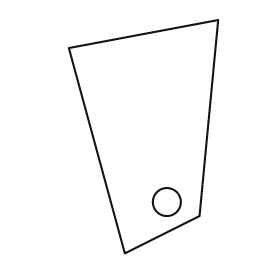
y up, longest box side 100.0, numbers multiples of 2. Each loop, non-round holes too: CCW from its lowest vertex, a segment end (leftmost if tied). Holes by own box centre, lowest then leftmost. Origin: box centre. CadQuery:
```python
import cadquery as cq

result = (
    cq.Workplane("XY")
    .moveTo(-8.0, -50.0)
    .lineTo(24.0, -34.0)
    .lineTo(32.0, 50.0)
    .lineTo(-32.0, 38.0)
    .close()
    .moveTo(10.0, -28.0)
    .circle(6.0)
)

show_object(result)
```